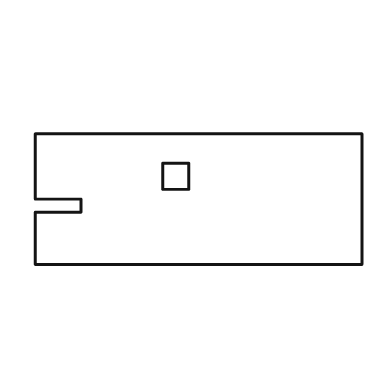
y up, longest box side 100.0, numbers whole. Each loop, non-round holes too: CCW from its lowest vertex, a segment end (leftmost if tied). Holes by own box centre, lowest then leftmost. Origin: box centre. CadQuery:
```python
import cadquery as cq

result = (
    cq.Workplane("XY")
    .moveTo(-50.0, -20.0)
    .lineTo(50.0, -20.0)
    .lineTo(50.0, 20.0)
    .lineTo(-50.0, 20.0)
    .lineTo(-50.0, 0.0)
    .lineTo(-36.0, 0.0)
    .lineTo(-36.0, -4.0)
    .lineTo(-50.0, -4.0)
    .close()
    .moveTo(-11.0, 3.0)
    .lineTo(-3.0, 3.0)
    .lineTo(-3.0, 11.0)
    .lineTo(-11.0, 11.0)
    .close()
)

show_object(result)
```